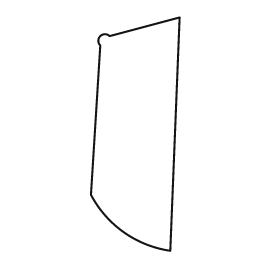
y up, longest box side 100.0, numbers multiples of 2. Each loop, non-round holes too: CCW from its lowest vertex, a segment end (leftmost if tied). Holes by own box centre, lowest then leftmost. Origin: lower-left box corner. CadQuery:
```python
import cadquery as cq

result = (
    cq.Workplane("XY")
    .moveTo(34.0, 0.0)
    .lineTo(38.0, 100.0)
    .lineTo(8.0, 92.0)
    .threePointArc((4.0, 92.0), (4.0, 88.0))
    .lineTo(0.0, 24.0)
    .threePointArc((14.0, 8.0), (34.0, 0.0))
    .close()
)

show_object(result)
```